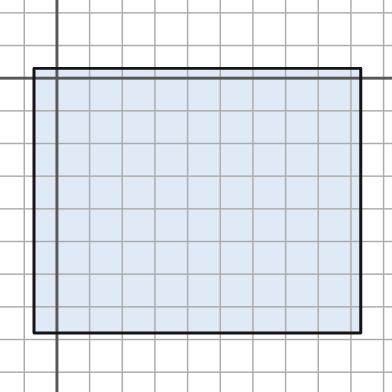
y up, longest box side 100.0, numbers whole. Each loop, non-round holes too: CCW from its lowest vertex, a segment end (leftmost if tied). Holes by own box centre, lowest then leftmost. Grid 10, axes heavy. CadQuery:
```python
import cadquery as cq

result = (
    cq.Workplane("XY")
    .moveTo(-7.0, -78.0)
    .lineTo(93.0, -78.0)
    .lineTo(93.0, 3.0)
    .lineTo(-7.0, 3.0)
    .close()
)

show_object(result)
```